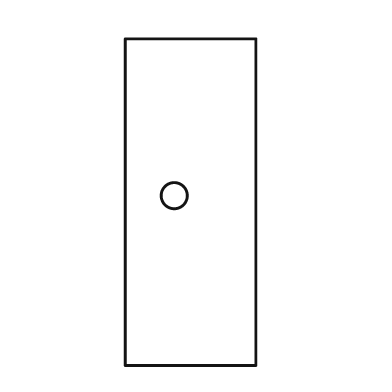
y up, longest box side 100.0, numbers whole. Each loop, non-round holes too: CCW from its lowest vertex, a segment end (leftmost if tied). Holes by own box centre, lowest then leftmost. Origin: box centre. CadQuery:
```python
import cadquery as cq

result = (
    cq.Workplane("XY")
    .moveTo(-20.0, -50.0)
    .lineTo(20.0, -50.0)
    .lineTo(20.0, 50.0)
    .lineTo(-20.0, 50.0)
    .close()
    .moveTo(-5.0, 2.0)
    .circle(4.0)
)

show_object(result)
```